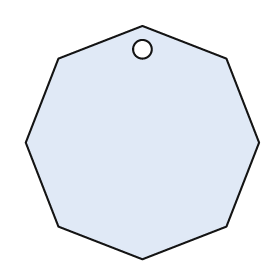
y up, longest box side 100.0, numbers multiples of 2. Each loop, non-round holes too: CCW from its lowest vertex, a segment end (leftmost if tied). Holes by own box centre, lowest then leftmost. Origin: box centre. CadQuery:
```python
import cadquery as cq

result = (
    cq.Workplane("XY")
    .moveTo(0.0, -50.0)
    .lineTo(36.0, -36.0)
    .lineTo(50.0, 0.0)
    .lineTo(36.0, 36.0)
    .lineTo(0.0, 50.0)
    .lineTo(-36.0, 36.0)
    .lineTo(-50.0, 0.0)
    .lineTo(-36.0, -36.0)
    .close()
    .moveTo(0.0, 40.0)
    .circle(4.0)
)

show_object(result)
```